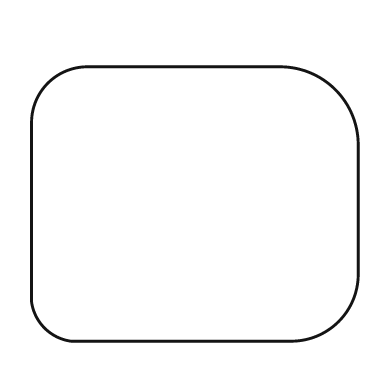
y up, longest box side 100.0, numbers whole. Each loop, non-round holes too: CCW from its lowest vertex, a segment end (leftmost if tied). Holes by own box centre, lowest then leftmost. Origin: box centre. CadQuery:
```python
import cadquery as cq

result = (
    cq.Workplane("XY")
    .moveTo(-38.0, -42.0)
    .lineTo(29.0, -42.0)
    .threePointArc((44.0, -36.0), (50.0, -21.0))
    .lineTo(50.0, 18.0)
    .threePointArc((43.0, 35.0), (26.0, 42.0))
    .lineTo(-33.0, 42.0)
    .threePointArc((-45.0, 37.0), (-50.0, 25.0))
    .lineTo(-50.0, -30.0)
    .threePointArc((-46.0, -38.0), (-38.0, -42.0))
    .close()
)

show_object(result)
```